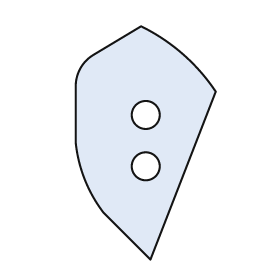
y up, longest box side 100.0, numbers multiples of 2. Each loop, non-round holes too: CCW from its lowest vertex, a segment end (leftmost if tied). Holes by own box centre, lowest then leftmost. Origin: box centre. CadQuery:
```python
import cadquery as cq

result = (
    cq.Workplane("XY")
    .moveTo(2.0, -50.0)
    .lineTo(30.0, 22.0)
    .threePointArc((16.0, 38.0), (-2.0, 50.0))
    .lineTo(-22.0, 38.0)
    .threePointArc((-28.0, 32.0), (-30.0, 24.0))
    .lineTo(-30.0, 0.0)
    .threePointArc((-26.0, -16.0), (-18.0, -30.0))
    .close()
    .moveTo(0.0, -10.0)
    .circle(6.0)
    .moveTo(0.0, 12.0)
    .circle(6.0)
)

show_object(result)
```